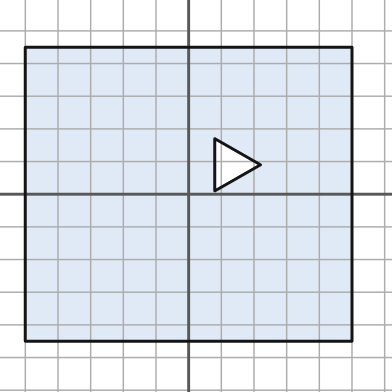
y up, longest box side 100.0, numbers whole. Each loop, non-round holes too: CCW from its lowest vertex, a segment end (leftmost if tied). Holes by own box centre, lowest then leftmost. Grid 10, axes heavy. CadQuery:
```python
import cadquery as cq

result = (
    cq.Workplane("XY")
    .moveTo(-50.0, -45.0)
    .lineTo(50.0, -45.0)
    .lineTo(50.0, 45.0)
    .lineTo(-50.0, 45.0)
    .close()
    .moveTo(8.0, 1.0)
    .lineTo(22.0, 9.0)
    .lineTo(8.0, 17.0)
    .close()
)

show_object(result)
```